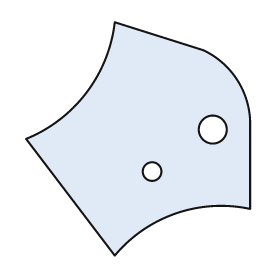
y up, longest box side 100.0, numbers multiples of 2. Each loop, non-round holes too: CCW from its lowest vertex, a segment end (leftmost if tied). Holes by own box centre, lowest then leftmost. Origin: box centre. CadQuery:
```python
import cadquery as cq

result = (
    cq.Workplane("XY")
    .moveTo(-10.0, -50.0)
    .threePointArc((16.0, -32.0), (48.0, -30.0))
    .lineTo(48.0, 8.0)
    .threePointArc((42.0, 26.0), (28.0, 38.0))
    .lineTo(-10.0, 50.0)
    .threePointArc((-22.0, 20.0), (-48.0, 0.0))
    .close()
    .moveTo(6.0, -14.0)
    .circle(4.0)
    .moveTo(32.0, 4.0)
    .circle(6.0)
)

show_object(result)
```